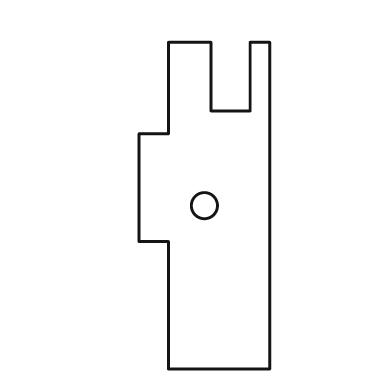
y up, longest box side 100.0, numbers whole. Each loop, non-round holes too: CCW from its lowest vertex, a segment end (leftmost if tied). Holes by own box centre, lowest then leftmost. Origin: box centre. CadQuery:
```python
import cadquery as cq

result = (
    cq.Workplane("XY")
    .moveTo(-11.0, -50.0)
    .lineTo(20.0, -50.0)
    .lineTo(20.0, 50.0)
    .lineTo(14.0, 50.0)
    .lineTo(14.0, 29.0)
    .lineTo(2.0, 29.0)
    .lineTo(2.0, 50.0)
    .lineTo(-11.0, 50.0)
    .lineTo(-11.0, 22.0)
    .lineTo(-20.0, 22.0)
    .lineTo(-20.0, -11.0)
    .lineTo(-11.0, -11.0)
    .close()
    .moveTo(0.0, 0.0)
    .circle(4.0)
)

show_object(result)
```